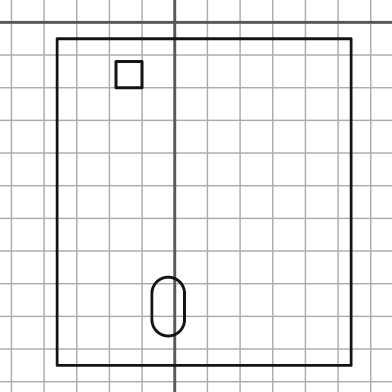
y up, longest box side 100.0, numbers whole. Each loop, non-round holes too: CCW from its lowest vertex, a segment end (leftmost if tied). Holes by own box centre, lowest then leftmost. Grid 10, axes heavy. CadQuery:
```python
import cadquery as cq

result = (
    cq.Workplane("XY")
    .moveTo(-36.0, -105.0)
    .lineTo(54.0, -105.0)
    .lineTo(54.0, -5.0)
    .lineTo(-36.0, -5.0)
    .close()
    .moveTo(-7.0, -91.0)
    .threePointArc((-2.0, -96.0), (3.0, -91.0))
    .lineTo(3.0, -83.0)
    .threePointArc((-2.0, -78.0), (-7.0, -83.0))
    .close()
    .moveTo(-18.0, -20.0)
    .lineTo(-10.0, -20.0)
    .lineTo(-10.0, -12.0)
    .lineTo(-18.0, -12.0)
    .close()
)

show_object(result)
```